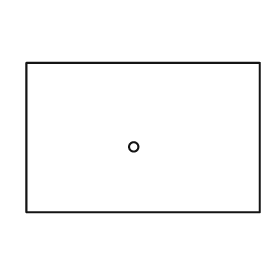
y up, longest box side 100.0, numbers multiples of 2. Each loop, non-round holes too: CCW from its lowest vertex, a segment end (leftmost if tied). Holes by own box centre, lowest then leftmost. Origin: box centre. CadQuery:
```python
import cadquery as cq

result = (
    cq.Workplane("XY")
    .moveTo(-50.0, -32.0)
    .lineTo(50.0, -32.0)
    .lineTo(50.0, 32.0)
    .lineTo(-50.0, 32.0)
    .close()
    .moveTo(-4.0, -4.0)
    .circle(2.0)
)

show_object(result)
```